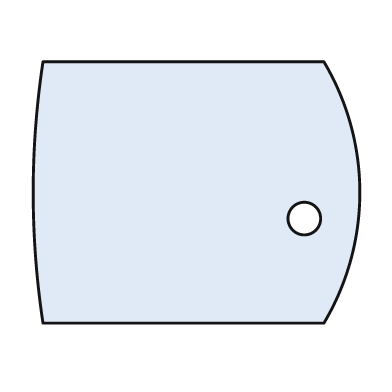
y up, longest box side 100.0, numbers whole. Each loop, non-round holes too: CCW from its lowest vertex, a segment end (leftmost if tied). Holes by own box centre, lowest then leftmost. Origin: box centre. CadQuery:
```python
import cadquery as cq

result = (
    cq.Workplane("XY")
    .moveTo(-47.0, -40.0)
    .lineTo(39.0, -40.0)
    .threePointArc((50.0, 0.0), (39.0, 40.0))
    .lineTo(-47.0, 40.0)
    .threePointArc((-50.0, 0.0), (-47.0, -40.0))
    .close()
    .moveTo(33.0, -8.0)
    .circle(5.0)
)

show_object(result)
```